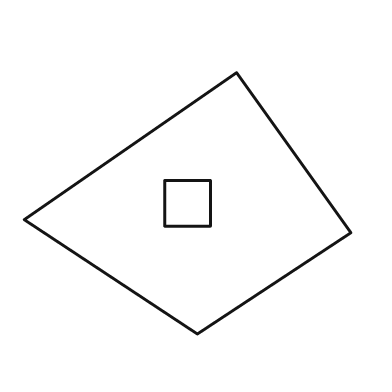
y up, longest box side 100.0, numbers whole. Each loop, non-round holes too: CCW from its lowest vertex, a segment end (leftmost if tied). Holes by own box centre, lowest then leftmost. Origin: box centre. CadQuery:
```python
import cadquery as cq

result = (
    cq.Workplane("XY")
    .moveTo(3.0, -40.0)
    .lineTo(50.0, -9.0)
    .lineTo(15.0, 40.0)
    .lineTo(-50.0, -5.0)
    .close()
    .moveTo(-7.0, -7.0)
    .lineTo(7.0, -7.0)
    .lineTo(7.0, 7.0)
    .lineTo(-7.0, 7.0)
    .close()
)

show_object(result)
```